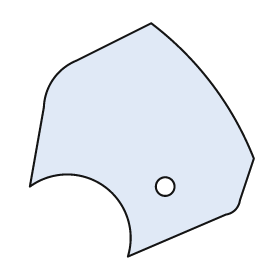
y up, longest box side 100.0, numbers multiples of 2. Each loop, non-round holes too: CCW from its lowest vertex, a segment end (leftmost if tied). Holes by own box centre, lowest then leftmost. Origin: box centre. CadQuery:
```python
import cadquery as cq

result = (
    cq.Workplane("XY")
    .moveTo(-6.0, -50.0)
    .lineTo(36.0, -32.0)
    .threePointArc((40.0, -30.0), (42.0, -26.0))
    .lineTo(48.0, -8.0)
    .threePointArc((30.0, 24.0), (4.0, 50.0))
    .lineTo(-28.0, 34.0)
    .threePointArc((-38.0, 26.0), (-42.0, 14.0))
    .lineTo(-48.0, -20.0)
    .threePointArc((-16.0, -20.0), (-6.0, -50.0))
    .close()
    .moveTo(10.0, -20.0)
    .circle(4.0)
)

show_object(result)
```